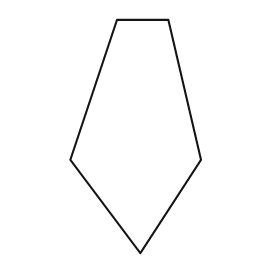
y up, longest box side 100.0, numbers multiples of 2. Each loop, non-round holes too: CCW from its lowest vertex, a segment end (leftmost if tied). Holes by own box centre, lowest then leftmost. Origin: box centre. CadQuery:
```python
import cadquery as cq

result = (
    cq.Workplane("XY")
    .moveTo(2.0, -50.0)
    .lineTo(28.0, -10.0)
    .lineTo(14.0, 50.0)
    .lineTo(-8.0, 50.0)
    .lineTo(-28.0, -10.0)
    .close()
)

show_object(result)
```